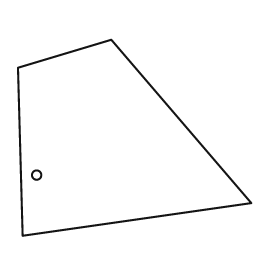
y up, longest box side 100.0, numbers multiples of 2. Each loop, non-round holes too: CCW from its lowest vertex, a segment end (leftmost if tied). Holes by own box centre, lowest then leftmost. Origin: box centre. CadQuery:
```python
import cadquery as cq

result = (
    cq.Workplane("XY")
    .moveTo(-48.0, -42.0)
    .lineTo(50.0, -28.0)
    .lineTo(-10.0, 42.0)
    .lineTo(-50.0, 30.0)
    .close()
    .moveTo(-42.0, -16.0)
    .circle(2.0)
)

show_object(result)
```